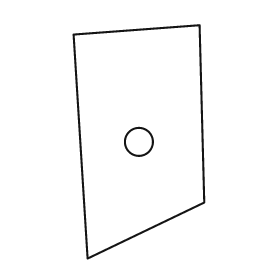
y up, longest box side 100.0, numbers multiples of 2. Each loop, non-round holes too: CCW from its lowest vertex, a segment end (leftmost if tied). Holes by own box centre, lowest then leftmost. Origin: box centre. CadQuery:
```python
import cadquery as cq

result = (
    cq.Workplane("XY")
    .moveTo(-22.0, -50.0)
    .lineTo(28.0, -26.0)
    .lineTo(26.0, 50.0)
    .lineTo(-28.0, 46.0)
    .close()
    .moveTo(0.0, 0.0)
    .circle(6.0)
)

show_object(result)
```